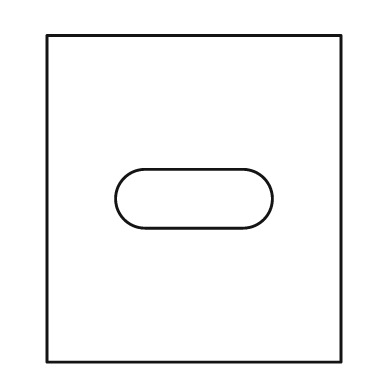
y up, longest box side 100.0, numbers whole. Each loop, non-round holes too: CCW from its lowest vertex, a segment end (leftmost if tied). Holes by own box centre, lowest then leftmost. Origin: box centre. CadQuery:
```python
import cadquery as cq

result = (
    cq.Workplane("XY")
    .moveTo(-45.0, -50.0)
    .lineTo(45.0, -50.0)
    .lineTo(45.0, 50.0)
    .lineTo(-45.0, 50.0)
    .close()
    .moveTo(-15.0, -9.0)
    .lineTo(15.0, -9.0)
    .threePointArc((24.0, 0.0), (15.0, 9.0))
    .lineTo(-15.0, 9.0)
    .threePointArc((-24.0, 0.0), (-15.0, -9.0))
    .close()
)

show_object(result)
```